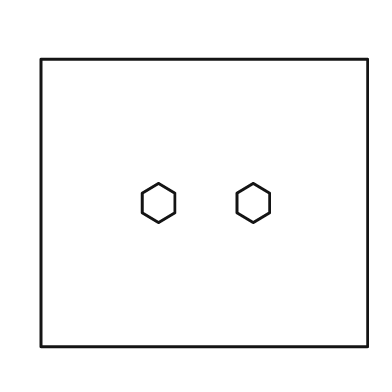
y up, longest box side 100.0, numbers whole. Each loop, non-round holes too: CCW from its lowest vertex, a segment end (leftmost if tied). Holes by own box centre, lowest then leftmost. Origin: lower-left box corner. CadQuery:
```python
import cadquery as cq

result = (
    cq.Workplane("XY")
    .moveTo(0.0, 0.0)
    .lineTo(100.0, 0.0)
    .lineTo(100.0, 88.0)
    .lineTo(0.0, 88.0)
    .close()
    .moveTo(36.0, 38.0)
    .lineTo(41.0, 41.0)
    .lineTo(41.0, 47.0)
    .lineTo(36.0, 50.0)
    .lineTo(31.0, 47.0)
    .lineTo(31.0, 41.0)
    .close()
    .moveTo(65.0, 38.0)
    .lineTo(70.0, 41.0)
    .lineTo(70.0, 47.0)
    .lineTo(65.0, 50.0)
    .lineTo(60.0, 47.0)
    .lineTo(60.0, 41.0)
    .close()
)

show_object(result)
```